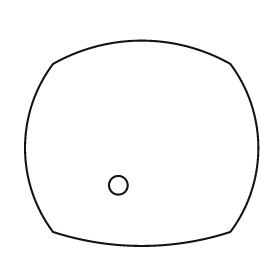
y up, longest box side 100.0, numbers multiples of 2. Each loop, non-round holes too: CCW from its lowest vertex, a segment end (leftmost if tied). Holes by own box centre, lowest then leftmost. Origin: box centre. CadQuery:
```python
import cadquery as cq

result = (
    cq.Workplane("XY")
    .moveTo(-38.0, -38.0)
    .threePointArc((0.0, -44.0), (38.0, -38.0))
    .threePointArc((50.0, -2.0), (38.0, 34.0))
    .threePointArc((0.0, 44.0), (-38.0, 34.0))
    .threePointArc((-50.0, -2.0), (-38.0, -38.0))
    .close()
    .moveTo(-10.0, -18.0)
    .circle(4.0)
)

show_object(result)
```